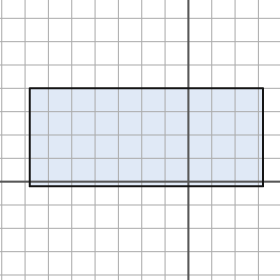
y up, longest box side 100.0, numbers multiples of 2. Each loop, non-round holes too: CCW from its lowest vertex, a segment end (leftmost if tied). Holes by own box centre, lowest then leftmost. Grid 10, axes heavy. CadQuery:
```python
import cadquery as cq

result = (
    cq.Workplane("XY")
    .moveTo(-68.0, -2.0)
    .lineTo(32.0, -2.0)
    .lineTo(32.0, 40.0)
    .lineTo(-68.0, 40.0)
    .close()
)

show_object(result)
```